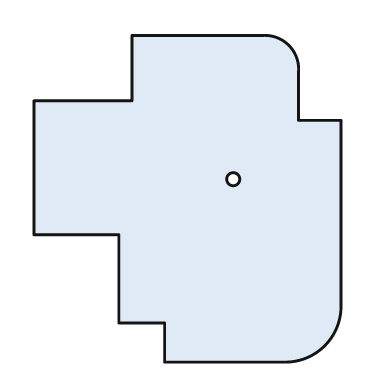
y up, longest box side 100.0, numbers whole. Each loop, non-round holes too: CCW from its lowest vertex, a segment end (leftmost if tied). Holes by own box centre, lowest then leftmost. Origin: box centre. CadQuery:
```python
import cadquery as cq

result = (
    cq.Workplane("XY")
    .moveTo(-7.0, -50.0)
    .lineTo(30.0, -50.0)
    .threePointArc((42.0, -45.0), (47.0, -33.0))
    .lineTo(47.0, 24.0)
    .lineTo(34.0, 24.0)
    .lineTo(34.0, 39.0)
    .threePointArc((31.0, 47.0), (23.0, 50.0))
    .lineTo(-17.0, 50.0)
    .lineTo(-17.0, 30.0)
    .lineTo(-47.0, 30.0)
    .lineTo(-47.0, -11.0)
    .lineTo(-21.0, -11.0)
    .lineTo(-21.0, -38.0)
    .lineTo(-7.0, -38.0)
    .close()
    .moveTo(14.0, 6.0)
    .circle(2.0)
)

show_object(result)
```